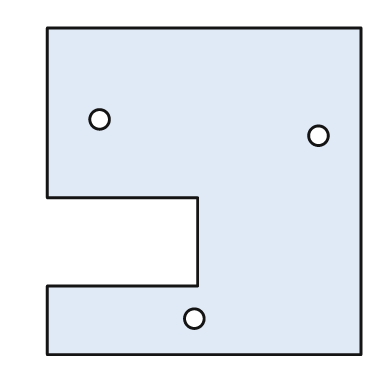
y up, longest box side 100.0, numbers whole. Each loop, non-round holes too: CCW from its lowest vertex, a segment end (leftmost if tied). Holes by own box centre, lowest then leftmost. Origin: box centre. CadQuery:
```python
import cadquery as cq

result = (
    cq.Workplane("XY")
    .moveTo(-48.0, -50.0)
    .lineTo(48.0, -50.0)
    .lineTo(48.0, 50.0)
    .lineTo(-48.0, 50.0)
    .lineTo(-48.0, -2.0)
    .lineTo(-2.0, -2.0)
    .lineTo(-2.0, -29.0)
    .lineTo(-48.0, -29.0)
    .close()
    .moveTo(-3.0, -39.0)
    .circle(3.0)
    .moveTo(35.0, 17.0)
    .circle(3.0)
    .moveTo(-32.0, 22.0)
    .circle(3.0)
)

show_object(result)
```